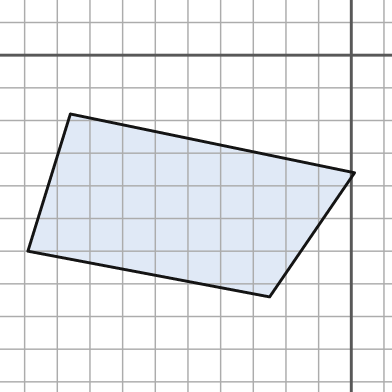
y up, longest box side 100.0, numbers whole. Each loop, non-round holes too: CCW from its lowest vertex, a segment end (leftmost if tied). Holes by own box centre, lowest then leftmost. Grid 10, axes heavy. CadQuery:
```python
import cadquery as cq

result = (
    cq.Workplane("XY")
    .moveTo(-25.0, -74.0)
    .lineTo(1.0, -36.0)
    .lineTo(-86.0, -18.0)
    .lineTo(-99.0, -60.0)
    .close()
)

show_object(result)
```